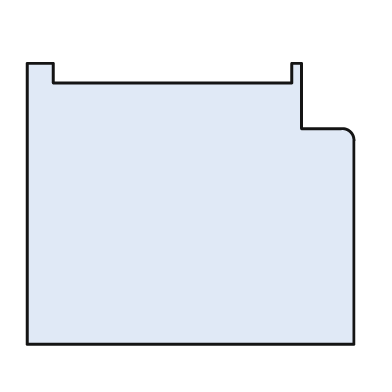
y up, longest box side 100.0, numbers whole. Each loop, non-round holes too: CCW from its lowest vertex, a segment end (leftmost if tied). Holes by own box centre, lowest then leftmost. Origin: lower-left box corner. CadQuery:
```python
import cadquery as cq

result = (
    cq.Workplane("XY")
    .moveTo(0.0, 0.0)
    .lineTo(100.0, 0.0)
    .lineTo(100.0, 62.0)
    .threePointArc((99.0, 65.0), (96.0, 66.0))
    .lineTo(84.0, 66.0)
    .lineTo(84.0, 86.0)
    .lineTo(81.0, 86.0)
    .lineTo(81.0, 80.0)
    .lineTo(8.0, 80.0)
    .lineTo(8.0, 86.0)
    .lineTo(0.0, 86.0)
    .close()
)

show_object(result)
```